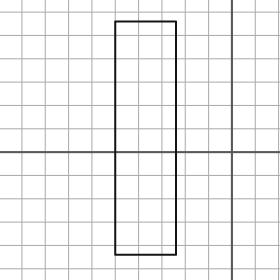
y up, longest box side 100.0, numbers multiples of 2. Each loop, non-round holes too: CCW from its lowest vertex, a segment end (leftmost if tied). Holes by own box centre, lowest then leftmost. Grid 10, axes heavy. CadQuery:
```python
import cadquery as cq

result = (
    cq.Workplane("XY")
    .moveTo(-50.0, -44.0)
    .lineTo(-24.0, -44.0)
    .lineTo(-24.0, 56.0)
    .lineTo(-50.0, 56.0)
    .close()
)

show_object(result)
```